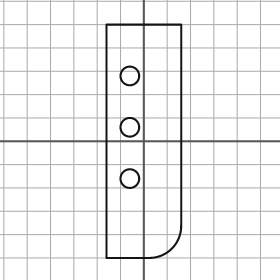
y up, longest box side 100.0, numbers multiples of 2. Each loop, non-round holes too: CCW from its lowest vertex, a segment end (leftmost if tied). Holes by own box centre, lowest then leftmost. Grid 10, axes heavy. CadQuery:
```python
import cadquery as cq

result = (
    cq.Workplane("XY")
    .moveTo(-16.0, -50.0)
    .lineTo(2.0, -50.0)
    .threePointArc((12.0, -46.0), (16.0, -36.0))
    .lineTo(16.0, 50.0)
    .lineTo(-16.0, 50.0)
    .close()
    .moveTo(-6.0, -16.0)
    .circle(4.0)
    .moveTo(-6.0, 6.0)
    .circle(4.0)
    .moveTo(-6.0, 28.0)
    .circle(4.0)
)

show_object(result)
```